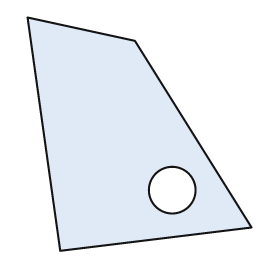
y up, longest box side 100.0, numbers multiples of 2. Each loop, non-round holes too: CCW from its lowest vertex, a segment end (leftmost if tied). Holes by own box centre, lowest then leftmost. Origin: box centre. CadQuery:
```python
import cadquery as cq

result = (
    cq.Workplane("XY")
    .moveTo(-34.0, -50.0)
    .lineTo(48.0, -40.0)
    .lineTo(-2.0, 40.0)
    .lineTo(-48.0, 50.0)
    .close()
    .moveTo(14.0, -24.0)
    .circle(10.0)
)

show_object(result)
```